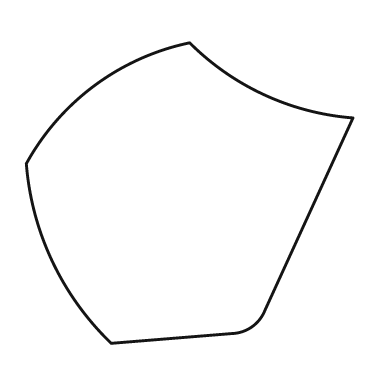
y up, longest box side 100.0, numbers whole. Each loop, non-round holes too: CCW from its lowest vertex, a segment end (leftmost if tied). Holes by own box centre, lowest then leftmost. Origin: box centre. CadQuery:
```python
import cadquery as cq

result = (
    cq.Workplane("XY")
    .moveTo(-24.0, -46.0)
    .lineTo(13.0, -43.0)
    .threePointArc((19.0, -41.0), (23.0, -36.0))
    .lineTo(50.0, 23.0)
    .threePointArc((23.0, 30.0), (0.0, 46.0))
    .threePointArc((-29.0, 33.0), (-50.0, 9.0))
    .threePointArc((-42.0, -21.0), (-24.0, -46.0))
    .close()
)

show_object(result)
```